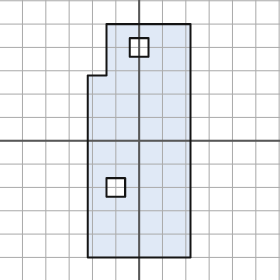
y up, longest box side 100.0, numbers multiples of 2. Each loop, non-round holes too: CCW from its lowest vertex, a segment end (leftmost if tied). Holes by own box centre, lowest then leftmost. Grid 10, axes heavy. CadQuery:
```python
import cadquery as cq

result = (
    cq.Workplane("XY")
    .moveTo(-22.0, -50.0)
    .lineTo(22.0, -50.0)
    .lineTo(22.0, 50.0)
    .lineTo(-14.0, 50.0)
    .lineTo(-14.0, 28.0)
    .lineTo(-22.0, 28.0)
    .close()
    .moveTo(-14.0, -24.0)
    .lineTo(-6.0, -24.0)
    .lineTo(-6.0, -16.0)
    .lineTo(-14.0, -16.0)
    .close()
    .moveTo(-4.0, 36.0)
    .lineTo(4.0, 36.0)
    .lineTo(4.0, 44.0)
    .lineTo(-4.0, 44.0)
    .close()
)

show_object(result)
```